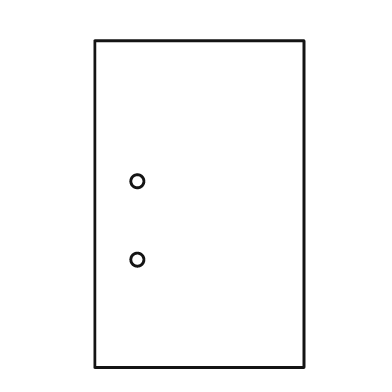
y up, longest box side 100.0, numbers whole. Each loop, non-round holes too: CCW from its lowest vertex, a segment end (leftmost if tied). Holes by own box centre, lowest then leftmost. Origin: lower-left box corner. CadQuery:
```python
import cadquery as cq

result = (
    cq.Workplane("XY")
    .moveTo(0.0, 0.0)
    .lineTo(64.0, 0.0)
    .lineTo(64.0, 100.0)
    .lineTo(0.0, 100.0)
    .close()
    .moveTo(13.0, 33.0)
    .circle(2.0)
    .moveTo(13.0, 57.0)
    .circle(2.0)
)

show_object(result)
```